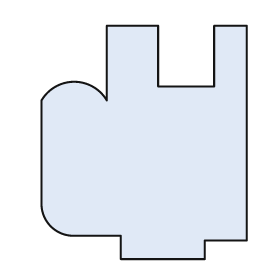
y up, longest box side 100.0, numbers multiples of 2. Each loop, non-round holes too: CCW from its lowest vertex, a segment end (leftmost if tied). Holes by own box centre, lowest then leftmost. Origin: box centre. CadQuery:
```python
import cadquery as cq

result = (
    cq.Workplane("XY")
    .moveTo(-10.0, -50.0)
    .lineTo(26.0, -50.0)
    .lineTo(26.0, -42.0)
    .lineTo(44.0, -42.0)
    .lineTo(44.0, 50.0)
    .lineTo(30.0, 50.0)
    .lineTo(30.0, 24.0)
    .lineTo(6.0, 24.0)
    .lineTo(6.0, 50.0)
    .lineTo(-16.0, 50.0)
    .lineTo(-16.0, 18.0)
    .threePointArc((-30.0, 26.0), (-44.0, 18.0))
    .lineTo(-44.0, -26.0)
    .threePointArc((-40.0, -36.0), (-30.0, -40.0))
    .lineTo(-10.0, -40.0)
    .close()
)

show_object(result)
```